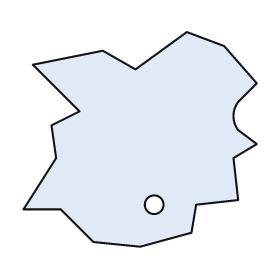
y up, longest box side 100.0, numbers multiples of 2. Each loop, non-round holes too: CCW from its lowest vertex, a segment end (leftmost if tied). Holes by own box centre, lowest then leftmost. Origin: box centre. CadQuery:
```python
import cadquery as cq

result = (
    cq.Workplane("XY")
    .moveTo(0.0, -46.0)
    .lineTo(22.0, -40.0)
    .lineTo(24.0, -28.0)
    .lineTo(42.0, -26.0)
    .lineTo(40.0, -8.0)
    .lineTo(50.0, -2.0)
    .lineTo(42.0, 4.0)
    .threePointArc((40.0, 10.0), (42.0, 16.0))
    .lineTo(50.0, 24.0)
    .lineTo(36.0, 40.0)
    .lineTo(20.0, 46.0)
    .lineTo(-2.0, 30.0)
    .lineTo(-16.0, 38.0)
    .lineTo(-46.0, 32.0)
    .lineTo(-26.0, 12.0)
    .lineTo(-38.0, 6.0)
    .lineTo(-36.0, -8.0)
    .lineTo(-50.0, -30.0)
    .lineTo(-34.0, -30.0)
    .lineTo(-20.0, -44.0)
    .close()
    .moveTo(6.0, -28.0)
    .circle(4.0)
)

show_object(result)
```